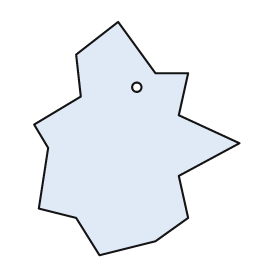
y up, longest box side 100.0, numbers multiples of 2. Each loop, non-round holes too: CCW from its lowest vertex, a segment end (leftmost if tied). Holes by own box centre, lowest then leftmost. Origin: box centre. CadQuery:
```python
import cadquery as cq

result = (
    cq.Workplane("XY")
    .moveTo(-16.0, -50.0)
    .lineTo(8.0, -44.0)
    .lineTo(22.0, -34.0)
    .lineTo(18.0, -16.0)
    .lineTo(44.0, -2.0)
    .lineTo(18.0, 10.0)
    .lineTo(22.0, 28.0)
    .lineTo(8.0, 28.0)
    .lineTo(-8.0, 50.0)
    .lineTo(-26.0, 36.0)
    .lineTo(-24.0, 18.0)
    .lineTo(-44.0, 6.0)
    .lineTo(-38.0, -4.0)
    .lineTo(-42.0, -30.0)
    .lineTo(-26.0, -34.0)
    .close()
    .moveTo(0.0, 22.0)
    .circle(2.0)
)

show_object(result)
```